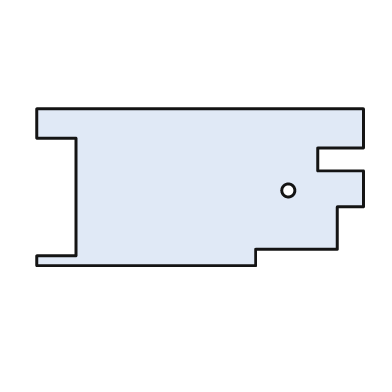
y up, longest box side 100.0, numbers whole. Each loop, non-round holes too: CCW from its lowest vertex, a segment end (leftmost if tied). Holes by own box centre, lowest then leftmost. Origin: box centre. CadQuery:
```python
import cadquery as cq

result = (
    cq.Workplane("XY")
    .moveTo(-50.0, -24.0)
    .lineTo(17.0, -24.0)
    .lineTo(17.0, -19.0)
    .lineTo(42.0, -19.0)
    .lineTo(42.0, -6.0)
    .lineTo(50.0, -6.0)
    .lineTo(50.0, 5.0)
    .lineTo(36.0, 5.0)
    .lineTo(36.0, 12.0)
    .lineTo(50.0, 12.0)
    .lineTo(50.0, 24.0)
    .lineTo(-50.0, 24.0)
    .lineTo(-50.0, 15.0)
    .lineTo(-38.0, 15.0)
    .lineTo(-38.0, -21.0)
    .lineTo(-50.0, -21.0)
    .close()
    .moveTo(27.0, -1.0)
    .circle(2.0)
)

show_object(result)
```